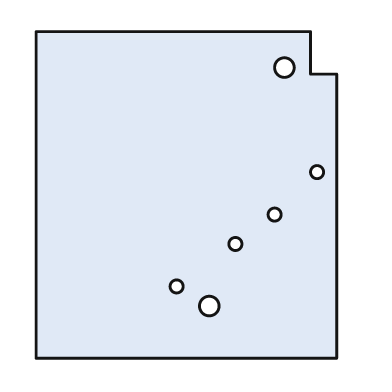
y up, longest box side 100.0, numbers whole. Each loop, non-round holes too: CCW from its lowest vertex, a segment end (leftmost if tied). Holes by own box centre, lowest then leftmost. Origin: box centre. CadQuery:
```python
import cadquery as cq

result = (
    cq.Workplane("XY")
    .moveTo(-46.0, -50.0)
    .lineTo(46.0, -50.0)
    .lineTo(46.0, 37.0)
    .lineTo(38.0, 37.0)
    .lineTo(38.0, 50.0)
    .lineTo(-46.0, 50.0)
    .close()
    .moveTo(7.0, -34.0)
    .circle(3.0)
    .moveTo(-3.0, -28.0)
    .circle(2.0)
    .moveTo(15.0, -15.0)
    .circle(2.0)
    .moveTo(27.0, -6.0)
    .circle(2.0)
    .moveTo(40.0, 7.0)
    .circle(2.0)
    .moveTo(30.0, 39.0)
    .circle(3.0)
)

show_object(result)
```